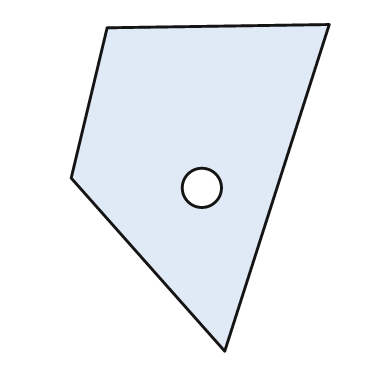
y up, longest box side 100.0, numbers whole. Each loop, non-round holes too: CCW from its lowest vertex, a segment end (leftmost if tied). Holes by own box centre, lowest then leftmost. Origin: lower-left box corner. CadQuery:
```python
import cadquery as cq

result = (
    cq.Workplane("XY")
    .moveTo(47.0, 0.0)
    .lineTo(79.0, 100.0)
    .lineTo(11.0, 99.0)
    .lineTo(0.0, 53.0)
    .close()
    .moveTo(40.0, 50.0)
    .circle(6.0)
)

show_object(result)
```